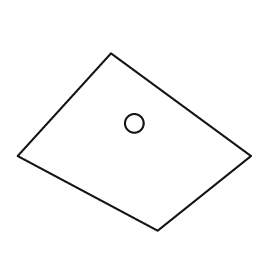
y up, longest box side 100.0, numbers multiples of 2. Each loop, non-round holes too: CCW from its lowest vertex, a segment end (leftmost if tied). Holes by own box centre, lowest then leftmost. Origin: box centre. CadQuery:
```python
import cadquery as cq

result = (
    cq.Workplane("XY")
    .moveTo(10.0, -38.0)
    .lineTo(50.0, -6.0)
    .lineTo(-10.0, 38.0)
    .lineTo(-50.0, -6.0)
    .close()
    .moveTo(0.0, 8.0)
    .circle(4.0)
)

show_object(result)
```